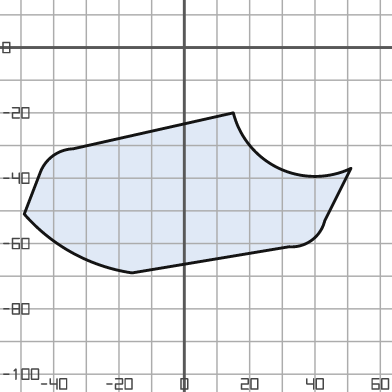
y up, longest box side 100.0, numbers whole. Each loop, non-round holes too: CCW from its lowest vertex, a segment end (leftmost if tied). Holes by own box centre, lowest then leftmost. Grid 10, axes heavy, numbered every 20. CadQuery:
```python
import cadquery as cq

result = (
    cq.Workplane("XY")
    .moveTo(-16.0, -69.0)
    .lineTo(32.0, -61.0)
    .threePointArc((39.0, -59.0), (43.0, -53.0))
    .lineTo(51.0, -37.0)
    .threePointArc((29.0, -37.0), (15.0, -20.0))
    .lineTo(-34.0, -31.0)
    .threePointArc((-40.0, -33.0), (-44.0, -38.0))
    .lineTo(-49.0, -51.0)
    .threePointArc((-34.0, -63.0), (-16.0, -69.0))
    .close()
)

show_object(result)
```